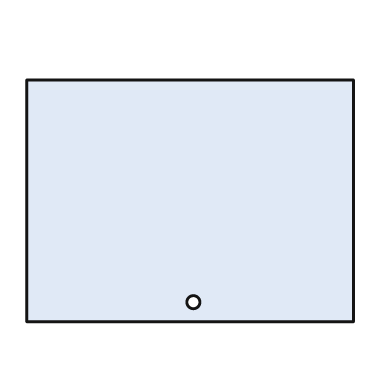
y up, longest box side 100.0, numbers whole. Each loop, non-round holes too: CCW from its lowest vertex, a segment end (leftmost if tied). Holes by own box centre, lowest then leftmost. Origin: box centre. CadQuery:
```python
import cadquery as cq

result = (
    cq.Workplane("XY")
    .moveTo(-50.0, -37.0)
    .lineTo(50.0, -37.0)
    .lineTo(50.0, 37.0)
    .lineTo(-50.0, 37.0)
    .close()
    .moveTo(1.0, -31.0)
    .circle(2.0)
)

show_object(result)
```